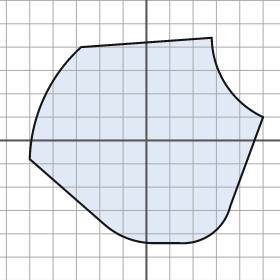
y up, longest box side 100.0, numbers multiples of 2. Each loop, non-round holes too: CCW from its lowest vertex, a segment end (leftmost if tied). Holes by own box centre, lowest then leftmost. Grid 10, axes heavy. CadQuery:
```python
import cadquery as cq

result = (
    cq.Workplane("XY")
    .moveTo(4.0, -44.0)
    .lineTo(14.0, -44.0)
    .threePointArc((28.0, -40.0), (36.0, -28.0))
    .lineTo(50.0, 10.0)
    .threePointArc((34.0, 24.0), (28.0, 44.0))
    .lineTo(-28.0, 40.0)
    .threePointArc((-44.0, 18.0), (-50.0, -8.0))
    .lineTo(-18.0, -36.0)
    .threePointArc((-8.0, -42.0), (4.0, -44.0))
    .close()
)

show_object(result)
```